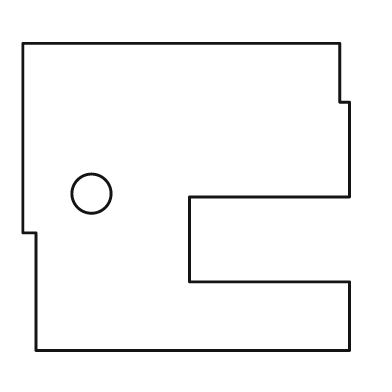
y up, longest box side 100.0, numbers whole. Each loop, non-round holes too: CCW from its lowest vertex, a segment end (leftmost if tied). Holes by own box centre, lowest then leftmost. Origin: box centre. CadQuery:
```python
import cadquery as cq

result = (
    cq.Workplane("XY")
    .moveTo(-46.0, -47.0)
    .lineTo(50.0, -47.0)
    .lineTo(50.0, -26.0)
    .lineTo(1.0, -26.0)
    .lineTo(1.0, 0.0)
    .lineTo(50.0, 0.0)
    .lineTo(50.0, 29.0)
    .lineTo(47.0, 29.0)
    .lineTo(47.0, 47.0)
    .lineTo(-50.0, 47.0)
    .lineTo(-50.0, -11.0)
    .lineTo(-46.0, -11.0)
    .close()
    .moveTo(-29.0, 1.0)
    .circle(6.0)
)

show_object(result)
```